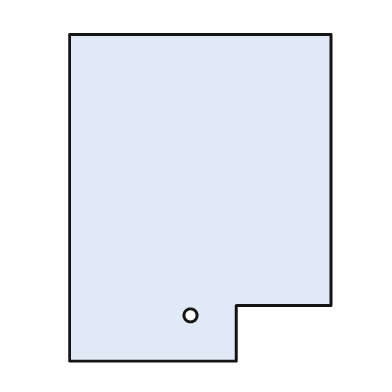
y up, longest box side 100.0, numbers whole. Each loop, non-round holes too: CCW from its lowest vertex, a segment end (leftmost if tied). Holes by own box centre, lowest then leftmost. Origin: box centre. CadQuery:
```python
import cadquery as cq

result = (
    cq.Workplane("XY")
    .moveTo(-40.0, -50.0)
    .lineTo(11.0, -50.0)
    .lineTo(11.0, -33.0)
    .lineTo(40.0, -33.0)
    .lineTo(40.0, 50.0)
    .lineTo(-40.0, 50.0)
    .close()
    .moveTo(-3.0, -36.0)
    .circle(2.0)
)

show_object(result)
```